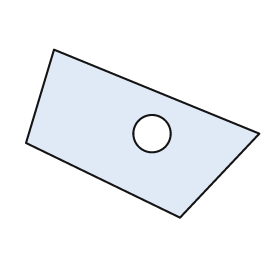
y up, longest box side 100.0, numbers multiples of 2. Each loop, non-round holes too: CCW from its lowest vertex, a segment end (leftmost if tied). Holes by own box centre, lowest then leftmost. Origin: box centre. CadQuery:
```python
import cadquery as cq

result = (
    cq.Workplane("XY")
    .moveTo(16.0, -36.0)
    .lineTo(50.0, 0.0)
    .lineTo(-38.0, 36.0)
    .lineTo(-50.0, -4.0)
    .close()
    .moveTo(4.0, 0.0)
    .circle(8.0)
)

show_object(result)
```